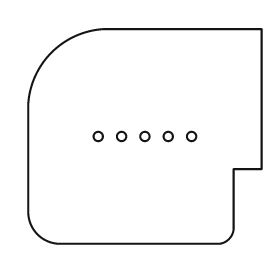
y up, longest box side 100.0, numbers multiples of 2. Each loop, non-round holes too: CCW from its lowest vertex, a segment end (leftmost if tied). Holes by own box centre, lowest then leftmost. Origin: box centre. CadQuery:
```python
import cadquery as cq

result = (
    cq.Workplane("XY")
    .moveTo(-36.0, -46.0)
    .lineTo(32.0, -46.0)
    .threePointArc((36.0, -44.0), (38.0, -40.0))
    .lineTo(38.0, -14.0)
    .lineTo(50.0, -14.0)
    .lineTo(50.0, 46.0)
    .lineTo(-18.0, 46.0)
    .threePointArc((-40.0, 36.0), (-50.0, 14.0))
    .lineTo(-50.0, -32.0)
    .threePointArc((-46.0, -42.0), (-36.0, -46.0))
    .close()
    .moveTo(-20.0, 0.0)
    .circle(2.0)
    .moveTo(-10.0, 0.0)
    .circle(2.0)
    .moveTo(0.0, 0.0)
    .circle(2.0)
    .moveTo(10.0, 0.0)
    .circle(2.0)
    .moveTo(20.0, 0.0)
    .circle(2.0)
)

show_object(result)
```